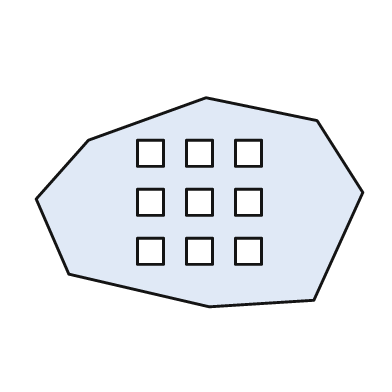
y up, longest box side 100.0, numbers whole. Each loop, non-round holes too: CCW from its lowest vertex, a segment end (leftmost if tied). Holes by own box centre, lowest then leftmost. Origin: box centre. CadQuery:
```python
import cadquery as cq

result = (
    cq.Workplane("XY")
    .moveTo(3.0, -32.0)
    .lineTo(35.0, -30.0)
    .lineTo(50.0, 3.0)
    .lineTo(36.0, 25.0)
    .lineTo(2.0, 32.0)
    .lineTo(-34.0, 19.0)
    .lineTo(-50.0, 1.0)
    .lineTo(-40.0, -22.0)
    .close()
    .moveTo(-19.0, -19.0)
    .lineTo(-11.0, -19.0)
    .lineTo(-11.0, -11.0)
    .lineTo(-19.0, -11.0)
    .close()
    .moveTo(-4.0, -19.0)
    .lineTo(4.0, -19.0)
    .lineTo(4.0, -11.0)
    .lineTo(-4.0, -11.0)
    .close()
    .moveTo(11.0, -19.0)
    .lineTo(19.0, -19.0)
    .lineTo(19.0, -11.0)
    .lineTo(11.0, -11.0)
    .close()
    .moveTo(-19.0, -4.0)
    .lineTo(-11.0, -4.0)
    .lineTo(-11.0, 4.0)
    .lineTo(-19.0, 4.0)
    .close()
    .moveTo(-4.0, -4.0)
    .lineTo(4.0, -4.0)
    .lineTo(4.0, 4.0)
    .lineTo(-4.0, 4.0)
    .close()
    .moveTo(11.0, -4.0)
    .lineTo(19.0, -4.0)
    .lineTo(19.0, 4.0)
    .lineTo(11.0, 4.0)
    .close()
    .moveTo(-19.0, 11.0)
    .lineTo(-11.0, 11.0)
    .lineTo(-11.0, 19.0)
    .lineTo(-19.0, 19.0)
    .close()
    .moveTo(-4.0, 11.0)
    .lineTo(4.0, 11.0)
    .lineTo(4.0, 19.0)
    .lineTo(-4.0, 19.0)
    .close()
    .moveTo(11.0, 11.0)
    .lineTo(19.0, 11.0)
    .lineTo(19.0, 19.0)
    .lineTo(11.0, 19.0)
    .close()
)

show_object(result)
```